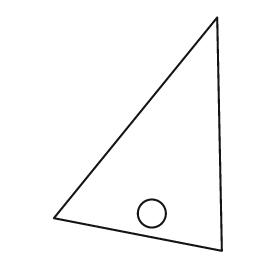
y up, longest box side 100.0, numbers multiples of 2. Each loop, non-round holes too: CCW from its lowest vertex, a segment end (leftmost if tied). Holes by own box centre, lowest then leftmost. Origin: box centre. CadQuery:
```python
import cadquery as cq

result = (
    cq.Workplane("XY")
    .moveTo(36.0, -50.0)
    .lineTo(34.0, 50.0)
    .lineTo(-36.0, -36.0)
    .close()
    .moveTo(6.0, -34.0)
    .circle(6.0)
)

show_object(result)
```